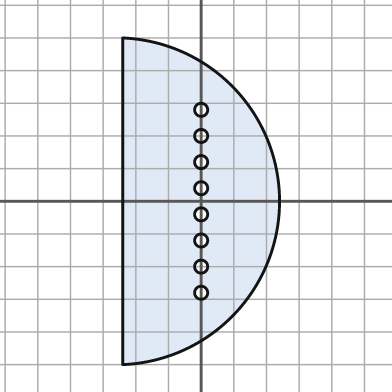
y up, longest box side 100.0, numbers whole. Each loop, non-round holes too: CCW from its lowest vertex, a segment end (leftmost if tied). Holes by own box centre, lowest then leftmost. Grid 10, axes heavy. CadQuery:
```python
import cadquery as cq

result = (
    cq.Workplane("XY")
    .moveTo(-24.0, -50.0)
    .threePointArc((24.0, 0.0), (-24.0, 50.0))
    .close()
    .moveTo(0.0, -28.0)
    .circle(2.0)
    .moveTo(0.0, -20.0)
    .circle(2.0)
    .moveTo(0.0, -12.0)
    .circle(2.0)
    .moveTo(0.0, -4.0)
    .circle(2.0)
    .moveTo(0.0, 4.0)
    .circle(2.0)
    .moveTo(0.0, 12.0)
    .circle(2.0)
    .moveTo(0.0, 20.0)
    .circle(2.0)
    .moveTo(0.0, 28.0)
    .circle(2.0)
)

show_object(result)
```